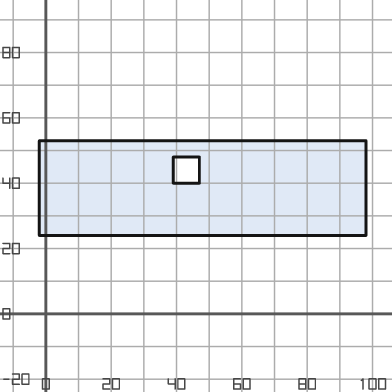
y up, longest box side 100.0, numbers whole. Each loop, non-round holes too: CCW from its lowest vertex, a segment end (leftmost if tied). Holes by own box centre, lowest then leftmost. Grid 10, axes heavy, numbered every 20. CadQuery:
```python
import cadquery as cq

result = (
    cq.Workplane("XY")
    .moveTo(-2.0, 24.0)
    .lineTo(98.0, 24.0)
    .lineTo(98.0, 53.0)
    .lineTo(-2.0, 53.0)
    .close()
    .moveTo(39.0, 40.0)
    .lineTo(47.0, 40.0)
    .lineTo(47.0, 48.0)
    .lineTo(39.0, 48.0)
    .close()
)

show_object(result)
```